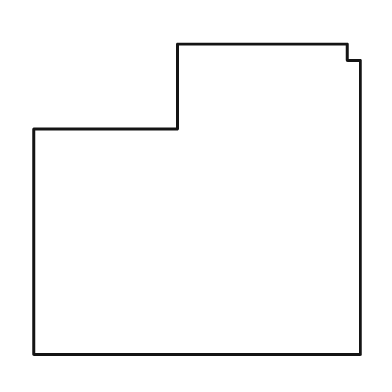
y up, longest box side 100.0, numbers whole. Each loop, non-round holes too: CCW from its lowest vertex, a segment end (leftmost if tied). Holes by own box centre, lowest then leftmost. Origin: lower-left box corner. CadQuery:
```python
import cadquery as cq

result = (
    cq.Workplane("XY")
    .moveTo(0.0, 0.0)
    .lineTo(100.0, 0.0)
    .lineTo(100.0, 90.0)
    .lineTo(96.0, 90.0)
    .lineTo(96.0, 95.0)
    .lineTo(44.0, 95.0)
    .lineTo(44.0, 69.0)
    .lineTo(0.0, 69.0)
    .close()
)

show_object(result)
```